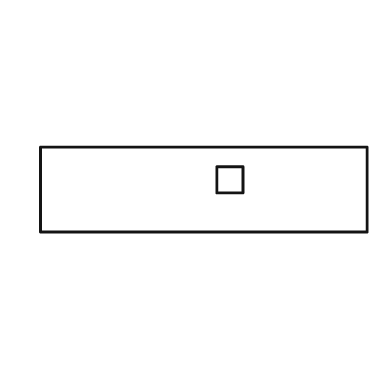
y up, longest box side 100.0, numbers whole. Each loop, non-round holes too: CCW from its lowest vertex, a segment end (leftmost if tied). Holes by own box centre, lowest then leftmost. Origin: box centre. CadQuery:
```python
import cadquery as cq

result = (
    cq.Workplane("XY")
    .moveTo(-50.0, -13.0)
    .lineTo(50.0, -13.0)
    .lineTo(50.0, 13.0)
    .lineTo(-50.0, 13.0)
    .close()
    .moveTo(4.0, -1.0)
    .lineTo(12.0, -1.0)
    .lineTo(12.0, 7.0)
    .lineTo(4.0, 7.0)
    .close()
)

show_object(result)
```